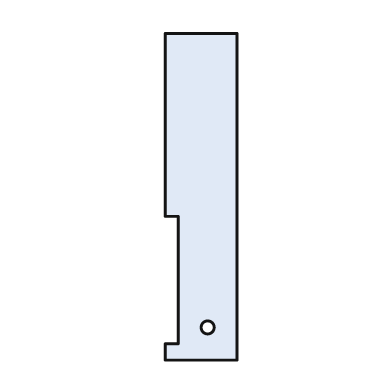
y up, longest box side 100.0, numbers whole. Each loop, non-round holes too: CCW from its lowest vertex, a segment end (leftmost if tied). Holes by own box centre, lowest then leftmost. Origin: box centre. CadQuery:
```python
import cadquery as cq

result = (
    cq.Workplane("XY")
    .moveTo(-11.0, -50.0)
    .lineTo(11.0, -50.0)
    .lineTo(11.0, 50.0)
    .lineTo(-11.0, 50.0)
    .lineTo(-11.0, -6.0)
    .lineTo(-7.0, -6.0)
    .lineTo(-7.0, -45.0)
    .lineTo(-11.0, -45.0)
    .close()
    .moveTo(2.0, -40.0)
    .circle(2.0)
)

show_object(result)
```